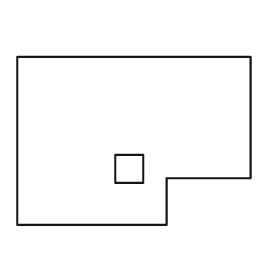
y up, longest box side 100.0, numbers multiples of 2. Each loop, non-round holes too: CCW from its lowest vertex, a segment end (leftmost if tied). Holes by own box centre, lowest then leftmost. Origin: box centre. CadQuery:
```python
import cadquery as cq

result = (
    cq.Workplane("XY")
    .moveTo(-50.0, -36.0)
    .lineTo(14.0, -36.0)
    .lineTo(14.0, -16.0)
    .lineTo(50.0, -16.0)
    .lineTo(50.0, 36.0)
    .lineTo(-50.0, 36.0)
    .close()
    .moveTo(-8.0, -18.0)
    .lineTo(4.0, -18.0)
    .lineTo(4.0, -6.0)
    .lineTo(-8.0, -6.0)
    .close()
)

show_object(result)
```